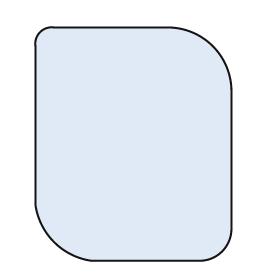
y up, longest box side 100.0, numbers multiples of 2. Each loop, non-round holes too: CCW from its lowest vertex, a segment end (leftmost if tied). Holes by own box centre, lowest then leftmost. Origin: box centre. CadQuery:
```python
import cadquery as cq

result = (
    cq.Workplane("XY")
    .moveTo(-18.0, -50.0)
    .lineTo(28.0, -50.0)
    .threePointArc((38.0, -46.0), (42.0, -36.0))
    .lineTo(42.0, 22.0)
    .threePointArc((34.0, 42.0), (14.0, 50.0))
    .lineTo(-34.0, 50.0)
    .threePointArc((-40.0, 48.0), (-42.0, 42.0))
    .lineTo(-42.0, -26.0)
    .threePointArc((-34.0, -42.0), (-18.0, -50.0))
    .close()
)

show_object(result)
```